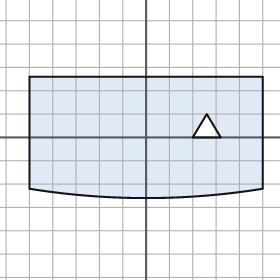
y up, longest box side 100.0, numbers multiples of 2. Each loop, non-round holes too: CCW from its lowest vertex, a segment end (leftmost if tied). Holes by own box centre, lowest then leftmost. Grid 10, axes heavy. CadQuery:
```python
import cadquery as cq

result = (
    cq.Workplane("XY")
    .moveTo(-50.0, -22.0)
    .threePointArc((0.0, -26.0), (50.0, -22.0))
    .lineTo(50.0, 26.0)
    .lineTo(-50.0, 26.0)
    .close()
    .moveTo(20.0, 0.0)
    .lineTo(32.0, 0.0)
    .lineTo(26.0, 10.0)
    .close()
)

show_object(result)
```